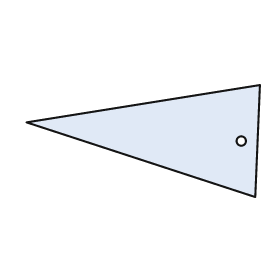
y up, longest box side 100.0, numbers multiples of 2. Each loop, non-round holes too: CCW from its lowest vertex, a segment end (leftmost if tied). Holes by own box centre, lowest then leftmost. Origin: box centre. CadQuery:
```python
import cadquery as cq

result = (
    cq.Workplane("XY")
    .moveTo(48.0, -24.0)
    .lineTo(50.0, 24.0)
    .lineTo(-50.0, 8.0)
    .close()
    .moveTo(42.0, 0.0)
    .circle(2.0)
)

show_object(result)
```